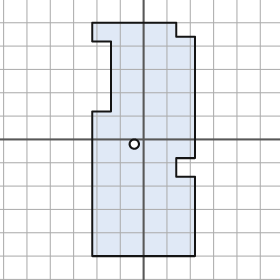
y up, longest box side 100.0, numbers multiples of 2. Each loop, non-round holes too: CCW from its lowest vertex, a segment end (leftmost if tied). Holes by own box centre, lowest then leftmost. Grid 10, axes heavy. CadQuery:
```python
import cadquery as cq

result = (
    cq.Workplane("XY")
    .moveTo(-22.0, -50.0)
    .lineTo(22.0, -50.0)
    .lineTo(22.0, -16.0)
    .lineTo(14.0, -16.0)
    .lineTo(14.0, -8.0)
    .lineTo(22.0, -8.0)
    .lineTo(22.0, 44.0)
    .lineTo(14.0, 44.0)
    .lineTo(14.0, 50.0)
    .lineTo(-22.0, 50.0)
    .lineTo(-22.0, 42.0)
    .lineTo(-14.0, 42.0)
    .lineTo(-14.0, 12.0)
    .lineTo(-22.0, 12.0)
    .close()
    .moveTo(-4.0, -2.0)
    .circle(2.0)
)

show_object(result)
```